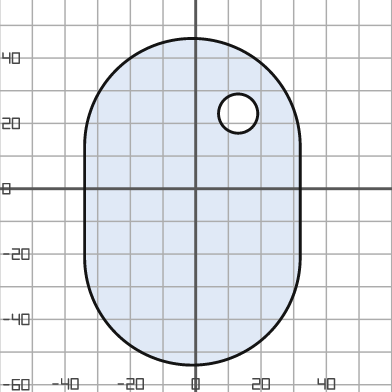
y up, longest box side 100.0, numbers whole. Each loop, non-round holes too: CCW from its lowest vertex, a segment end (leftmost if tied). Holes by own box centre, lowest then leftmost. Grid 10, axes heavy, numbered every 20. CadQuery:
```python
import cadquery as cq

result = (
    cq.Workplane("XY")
    .moveTo(-34.0, -21.0)
    .threePointArc((-1.0, -54.0), (32.0, -21.0))
    .lineTo(32.0, 13.0)
    .threePointArc((-1.0, 46.0), (-34.0, 13.0))
    .close()
    .moveTo(13.0, 23.0)
    .circle(6.0)
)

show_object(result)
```